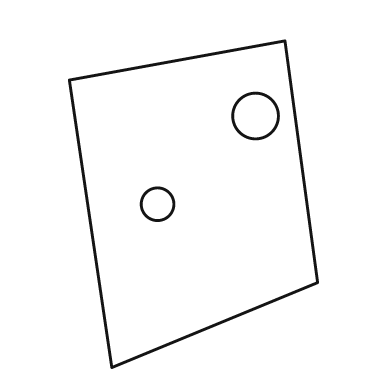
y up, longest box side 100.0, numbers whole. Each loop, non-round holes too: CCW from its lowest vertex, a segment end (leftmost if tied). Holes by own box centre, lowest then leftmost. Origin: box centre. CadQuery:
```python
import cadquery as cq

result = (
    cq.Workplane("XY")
    .moveTo(-25.0, -50.0)
    .lineTo(38.0, -24.0)
    .lineTo(28.0, 50.0)
    .lineTo(-38.0, 38.0)
    .close()
    .moveTo(-11.0, 0.0)
    .circle(5.0)
    .moveTo(19.0, 27.0)
    .circle(7.0)
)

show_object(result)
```